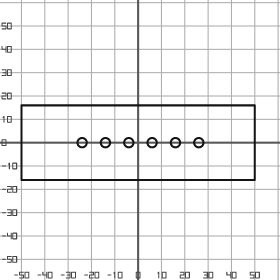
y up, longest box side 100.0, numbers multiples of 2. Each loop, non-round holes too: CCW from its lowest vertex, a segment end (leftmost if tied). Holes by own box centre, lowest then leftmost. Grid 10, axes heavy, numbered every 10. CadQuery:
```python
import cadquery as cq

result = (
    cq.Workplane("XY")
    .moveTo(-50.0, -16.0)
    .lineTo(50.0, -16.0)
    .lineTo(50.0, 16.0)
    .lineTo(-50.0, 16.0)
    .close()
    .moveTo(-24.0, 0.0)
    .circle(2.0)
    .moveTo(-14.0, 0.0)
    .circle(2.0)
    .moveTo(-4.0, 0.0)
    .circle(2.0)
    .moveTo(6.0, 0.0)
    .circle(2.0)
    .moveTo(16.0, 0.0)
    .circle(2.0)
    .moveTo(26.0, 0.0)
    .circle(2.0)
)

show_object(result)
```